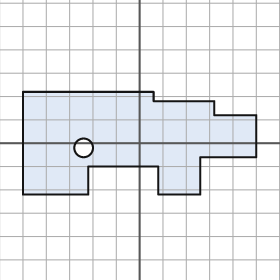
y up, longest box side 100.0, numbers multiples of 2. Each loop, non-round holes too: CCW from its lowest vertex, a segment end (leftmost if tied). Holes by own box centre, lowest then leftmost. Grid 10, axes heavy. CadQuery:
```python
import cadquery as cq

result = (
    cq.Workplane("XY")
    .moveTo(-50.0, -22.0)
    .lineTo(-22.0, -22.0)
    .lineTo(-22.0, -10.0)
    .lineTo(8.0, -10.0)
    .lineTo(8.0, -22.0)
    .lineTo(26.0, -22.0)
    .lineTo(26.0, -6.0)
    .lineTo(50.0, -6.0)
    .lineTo(50.0, 12.0)
    .lineTo(32.0, 12.0)
    .lineTo(32.0, 18.0)
    .lineTo(6.0, 18.0)
    .lineTo(6.0, 22.0)
    .lineTo(-50.0, 22.0)
    .close()
    .moveTo(-24.0, -2.0)
    .circle(4.0)
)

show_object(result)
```